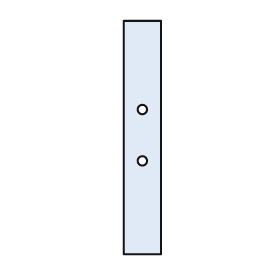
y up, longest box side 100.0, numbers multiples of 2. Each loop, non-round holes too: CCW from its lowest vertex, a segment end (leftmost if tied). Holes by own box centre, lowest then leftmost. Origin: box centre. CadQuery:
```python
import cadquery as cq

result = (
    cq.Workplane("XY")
    .moveTo(-8.0, -50.0)
    .lineTo(8.0, -50.0)
    .lineTo(8.0, 50.0)
    .lineTo(-8.0, 50.0)
    .close()
    .moveTo(0.0, -10.0)
    .circle(2.0)
    .moveTo(0.0, 12.0)
    .circle(2.0)
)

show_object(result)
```